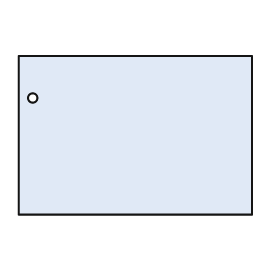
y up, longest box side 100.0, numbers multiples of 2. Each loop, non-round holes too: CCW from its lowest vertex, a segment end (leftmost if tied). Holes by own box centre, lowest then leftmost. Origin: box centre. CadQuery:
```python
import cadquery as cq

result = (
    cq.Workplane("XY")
    .moveTo(-50.0, -34.0)
    .lineTo(50.0, -34.0)
    .lineTo(50.0, 34.0)
    .lineTo(-50.0, 34.0)
    .close()
    .moveTo(-44.0, 16.0)
    .circle(2.0)
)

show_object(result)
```